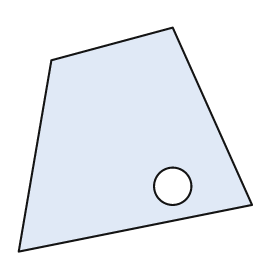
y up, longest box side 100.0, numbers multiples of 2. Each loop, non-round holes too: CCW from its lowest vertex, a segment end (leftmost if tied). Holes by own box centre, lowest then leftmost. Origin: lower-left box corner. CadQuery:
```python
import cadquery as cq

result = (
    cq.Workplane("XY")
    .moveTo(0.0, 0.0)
    .lineTo(100.0, 20.0)
    .lineTo(66.0, 96.0)
    .lineTo(14.0, 82.0)
    .close()
    .moveTo(66.0, 28.0)
    .circle(8.0)
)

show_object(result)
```